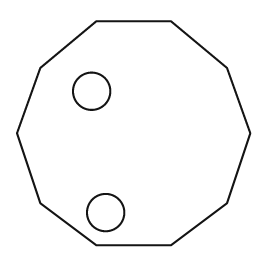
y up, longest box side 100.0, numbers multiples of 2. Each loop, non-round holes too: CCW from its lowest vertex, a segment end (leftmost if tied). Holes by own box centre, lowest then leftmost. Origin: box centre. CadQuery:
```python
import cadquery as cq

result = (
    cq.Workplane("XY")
    .moveTo(-16.0, -48.0)
    .lineTo(16.0, -48.0)
    .lineTo(40.0, -30.0)
    .lineTo(50.0, 0.0)
    .lineTo(40.0, 28.0)
    .lineTo(16.0, 48.0)
    .lineTo(-16.0, 48.0)
    .lineTo(-40.0, 28.0)
    .lineTo(-50.0, 0.0)
    .lineTo(-40.0, -30.0)
    .close()
    .moveTo(-12.0, -34.0)
    .circle(8.0)
    .moveTo(-18.0, 18.0)
    .circle(8.0)
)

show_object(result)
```